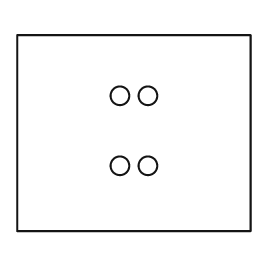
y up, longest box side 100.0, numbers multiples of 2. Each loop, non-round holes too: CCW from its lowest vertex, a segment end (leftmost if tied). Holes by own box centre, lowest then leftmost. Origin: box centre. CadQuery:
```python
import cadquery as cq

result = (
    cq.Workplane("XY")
    .moveTo(-50.0, -42.0)
    .lineTo(50.0, -42.0)
    .lineTo(50.0, 42.0)
    .lineTo(-50.0, 42.0)
    .close()
    .moveTo(-6.0, -14.0)
    .circle(4.0)
    .moveTo(6.0, -14.0)
    .circle(4.0)
    .moveTo(-6.0, 16.0)
    .circle(4.0)
    .moveTo(6.0, 16.0)
    .circle(4.0)
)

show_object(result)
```